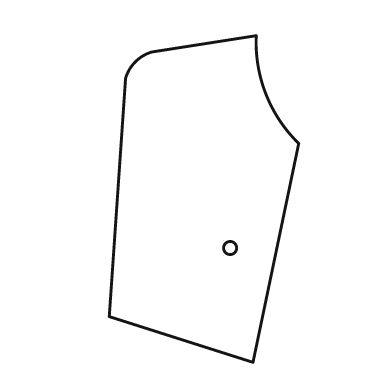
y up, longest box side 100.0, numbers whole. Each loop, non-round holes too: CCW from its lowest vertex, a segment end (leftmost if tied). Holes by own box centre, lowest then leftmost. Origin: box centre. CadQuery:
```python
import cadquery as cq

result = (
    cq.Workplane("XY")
    .moveTo(15.0, -50.0)
    .lineTo(29.0, 17.0)
    .threePointArc((19.0, 32.0), (16.0, 50.0))
    .lineTo(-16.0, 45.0)
    .threePointArc((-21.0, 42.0), (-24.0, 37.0))
    .lineTo(-29.0, -36.0)
    .close()
    .moveTo(8.0, -15.0)
    .circle(2.0)
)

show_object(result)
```